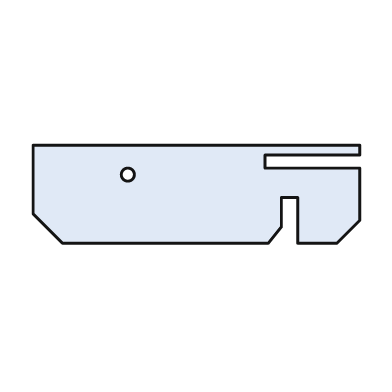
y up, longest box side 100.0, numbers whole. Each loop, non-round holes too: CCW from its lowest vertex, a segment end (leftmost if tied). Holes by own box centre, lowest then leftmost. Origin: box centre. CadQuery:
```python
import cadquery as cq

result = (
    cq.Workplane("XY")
    .moveTo(-41.0, -15.0)
    .lineTo(22.0, -15.0)
    .lineTo(26.0, -10.0)
    .lineTo(26.0, -1.0)
    .lineTo(31.0, -1.0)
    .lineTo(31.0, -15.0)
    .lineTo(43.0, -15.0)
    .lineTo(50.0, -8.0)
    .lineTo(50.0, 8.0)
    .lineTo(21.0, 8.0)
    .lineTo(21.0, 12.0)
    .lineTo(50.0, 12.0)
    .lineTo(50.0, 15.0)
    .lineTo(-50.0, 15.0)
    .lineTo(-50.0, -6.0)
    .close()
    .moveTo(-21.0, 6.0)
    .circle(2.0)
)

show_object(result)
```